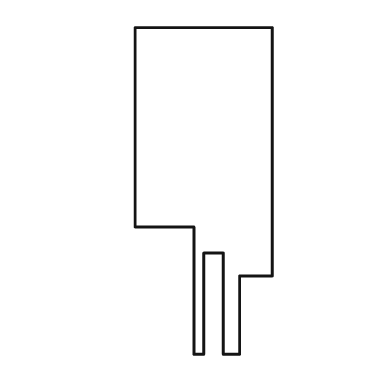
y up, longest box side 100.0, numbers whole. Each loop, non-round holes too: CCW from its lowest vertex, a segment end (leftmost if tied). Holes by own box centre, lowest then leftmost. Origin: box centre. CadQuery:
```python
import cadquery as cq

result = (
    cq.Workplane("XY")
    .moveTo(-3.0, -50.0)
    .lineTo(0.0, -50.0)
    .lineTo(0.0, -19.0)
    .lineTo(6.0, -19.0)
    .lineTo(6.0, -50.0)
    .lineTo(11.0, -50.0)
    .lineTo(11.0, -26.0)
    .lineTo(21.0, -26.0)
    .lineTo(21.0, 50.0)
    .lineTo(-21.0, 50.0)
    .lineTo(-21.0, -11.0)
    .lineTo(-3.0, -11.0)
    .close()
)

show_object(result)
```